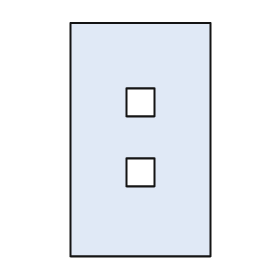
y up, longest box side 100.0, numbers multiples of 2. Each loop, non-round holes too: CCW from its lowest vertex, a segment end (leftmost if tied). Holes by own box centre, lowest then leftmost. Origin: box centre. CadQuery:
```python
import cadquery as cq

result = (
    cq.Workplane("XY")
    .moveTo(-30.0, -50.0)
    .lineTo(30.0, -50.0)
    .lineTo(30.0, 50.0)
    .lineTo(-30.0, 50.0)
    .close()
    .moveTo(-6.0, -20.0)
    .lineTo(6.0, -20.0)
    .lineTo(6.0, -8.0)
    .lineTo(-6.0, -8.0)
    .close()
    .moveTo(-6.0, 10.0)
    .lineTo(6.0, 10.0)
    .lineTo(6.0, 22.0)
    .lineTo(-6.0, 22.0)
    .close()
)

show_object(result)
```